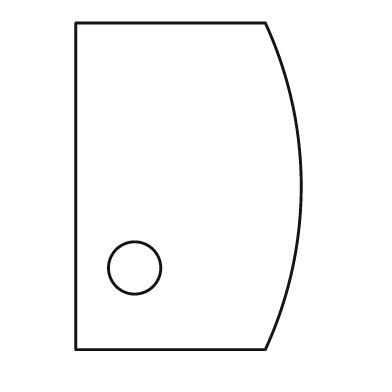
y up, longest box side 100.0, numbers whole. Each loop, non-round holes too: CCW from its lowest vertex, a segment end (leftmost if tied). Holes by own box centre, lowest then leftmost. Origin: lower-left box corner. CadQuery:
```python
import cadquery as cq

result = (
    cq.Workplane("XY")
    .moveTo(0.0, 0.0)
    .lineTo(58.0, 0.0)
    .threePointArc((69.0, 50.0), (58.0, 100.0))
    .lineTo(0.0, 100.0)
    .close()
    .moveTo(18.0, 25.0)
    .circle(8.0)
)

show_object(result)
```